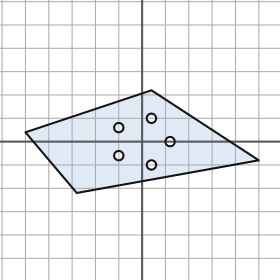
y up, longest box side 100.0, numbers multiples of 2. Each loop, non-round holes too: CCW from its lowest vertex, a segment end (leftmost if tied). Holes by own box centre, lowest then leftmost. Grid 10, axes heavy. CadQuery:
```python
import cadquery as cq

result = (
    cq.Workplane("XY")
    .moveTo(-28.0, -22.0)
    .lineTo(50.0, -8.0)
    .lineTo(4.0, 22.0)
    .lineTo(-50.0, 4.0)
    .close()
    .moveTo(4.0, -10.0)
    .circle(2.0)
    .moveTo(-10.0, -6.0)
    .circle(2.0)
    .moveTo(12.0, 0.0)
    .circle(2.0)
    .moveTo(-10.0, 6.0)
    .circle(2.0)
    .moveTo(4.0, 10.0)
    .circle(2.0)
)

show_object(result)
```